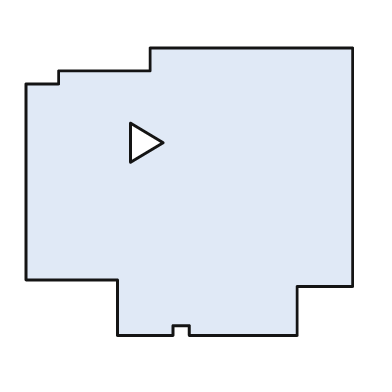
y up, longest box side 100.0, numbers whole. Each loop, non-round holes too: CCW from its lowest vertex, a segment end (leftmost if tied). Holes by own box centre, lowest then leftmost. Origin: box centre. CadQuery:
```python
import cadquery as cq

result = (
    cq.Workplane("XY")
    .moveTo(-22.0, -44.0)
    .lineTo(-5.0, -44.0)
    .lineTo(-5.0, -41.0)
    .lineTo(0.0, -41.0)
    .lineTo(0.0, -44.0)
    .lineTo(33.0, -44.0)
    .lineTo(33.0, -29.0)
    .lineTo(50.0, -29.0)
    .lineTo(50.0, 44.0)
    .lineTo(-12.0, 44.0)
    .lineTo(-12.0, 37.0)
    .lineTo(-40.0, 37.0)
    .lineTo(-40.0, 33.0)
    .lineTo(-50.0, 33.0)
    .lineTo(-50.0, -27.0)
    .lineTo(-22.0, -27.0)
    .close()
    .moveTo(-18.0, 9.0)
    .lineTo(-8.0, 15.0)
    .lineTo(-18.0, 21.0)
    .close()
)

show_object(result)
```